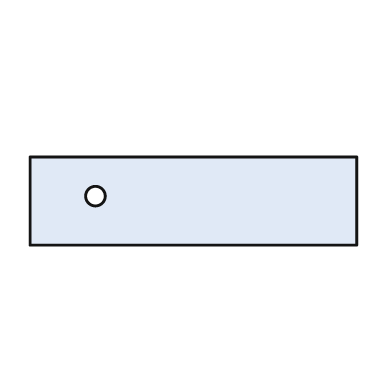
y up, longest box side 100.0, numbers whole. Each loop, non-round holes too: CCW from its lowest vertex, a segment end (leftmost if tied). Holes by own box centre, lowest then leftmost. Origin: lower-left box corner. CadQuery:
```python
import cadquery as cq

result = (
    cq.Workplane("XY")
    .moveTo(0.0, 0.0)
    .lineTo(100.0, 0.0)
    .lineTo(100.0, 27.0)
    .lineTo(0.0, 27.0)
    .close()
    .moveTo(20.0, 15.0)
    .circle(3.0)
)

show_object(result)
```